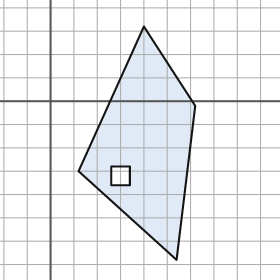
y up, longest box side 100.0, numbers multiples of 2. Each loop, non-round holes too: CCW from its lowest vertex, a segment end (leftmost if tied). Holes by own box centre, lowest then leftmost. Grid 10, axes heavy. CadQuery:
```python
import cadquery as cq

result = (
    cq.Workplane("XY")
    .moveTo(54.0, -68.0)
    .lineTo(62.0, -2.0)
    .lineTo(40.0, 32.0)
    .lineTo(12.0, -30.0)
    .close()
    .moveTo(26.0, -36.0)
    .lineTo(34.0, -36.0)
    .lineTo(34.0, -28.0)
    .lineTo(26.0, -28.0)
    .close()
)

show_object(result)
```